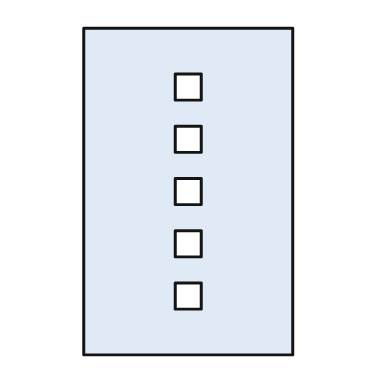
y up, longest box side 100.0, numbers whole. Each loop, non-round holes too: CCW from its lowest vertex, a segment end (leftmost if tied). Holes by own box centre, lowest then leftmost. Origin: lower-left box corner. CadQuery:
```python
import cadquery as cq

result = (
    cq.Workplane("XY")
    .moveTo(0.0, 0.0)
    .lineTo(64.0, 0.0)
    .lineTo(64.0, 100.0)
    .lineTo(0.0, 100.0)
    .close()
    .moveTo(28.0, 14.0)
    .lineTo(36.0, 14.0)
    .lineTo(36.0, 22.0)
    .lineTo(28.0, 22.0)
    .close()
    .moveTo(28.0, 30.0)
    .lineTo(36.0, 30.0)
    .lineTo(36.0, 38.0)
    .lineTo(28.0, 38.0)
    .close()
    .moveTo(28.0, 46.0)
    .lineTo(36.0, 46.0)
    .lineTo(36.0, 54.0)
    .lineTo(28.0, 54.0)
    .close()
    .moveTo(28.0, 62.0)
    .lineTo(36.0, 62.0)
    .lineTo(36.0, 70.0)
    .lineTo(28.0, 70.0)
    .close()
    .moveTo(28.0, 78.0)
    .lineTo(36.0, 78.0)
    .lineTo(36.0, 86.0)
    .lineTo(28.0, 86.0)
    .close()
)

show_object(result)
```